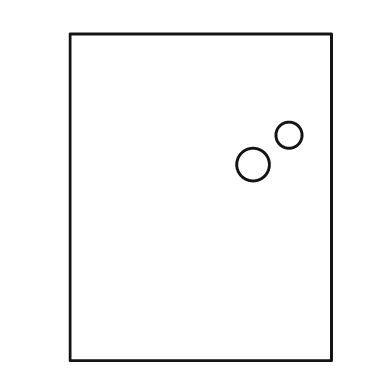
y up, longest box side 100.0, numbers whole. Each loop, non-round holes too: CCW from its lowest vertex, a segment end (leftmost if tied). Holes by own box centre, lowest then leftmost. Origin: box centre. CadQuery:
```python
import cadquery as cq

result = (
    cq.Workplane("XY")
    .moveTo(-40.0, -50.0)
    .lineTo(40.0, -50.0)
    .lineTo(40.0, 50.0)
    .lineTo(-40.0, 50.0)
    .close()
    .moveTo(16.0, 10.0)
    .circle(5.0)
    .moveTo(27.0, 19.0)
    .circle(4.0)
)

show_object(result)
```